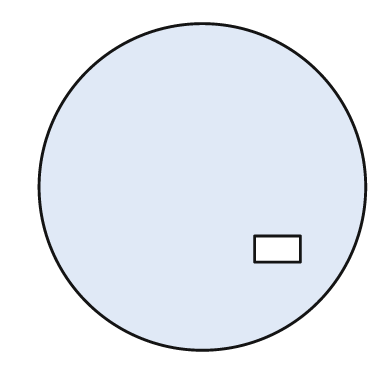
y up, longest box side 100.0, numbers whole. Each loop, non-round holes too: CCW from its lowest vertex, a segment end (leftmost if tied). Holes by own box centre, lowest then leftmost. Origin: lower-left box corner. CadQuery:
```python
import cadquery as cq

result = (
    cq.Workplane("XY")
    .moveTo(50.0, 50.0)
    .circle(50.0)
    .moveTo(66.0, 27.0)
    .lineTo(80.0, 27.0)
    .lineTo(80.0, 35.0)
    .lineTo(66.0, 35.0)
    .close()
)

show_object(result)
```